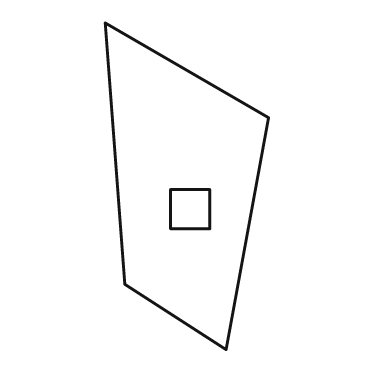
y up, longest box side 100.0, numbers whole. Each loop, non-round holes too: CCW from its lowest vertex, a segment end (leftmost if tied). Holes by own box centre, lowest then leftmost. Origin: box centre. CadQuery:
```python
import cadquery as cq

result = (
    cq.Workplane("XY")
    .moveTo(12.0, -50.0)
    .lineTo(25.0, 21.0)
    .lineTo(-25.0, 50.0)
    .lineTo(-19.0, -30.0)
    .close()
    .moveTo(-5.0, -13.0)
    .lineTo(7.0, -13.0)
    .lineTo(7.0, -1.0)
    .lineTo(-5.0, -1.0)
    .close()
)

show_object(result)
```